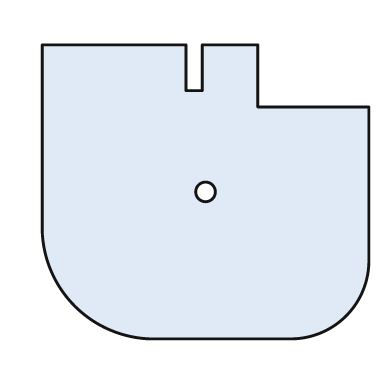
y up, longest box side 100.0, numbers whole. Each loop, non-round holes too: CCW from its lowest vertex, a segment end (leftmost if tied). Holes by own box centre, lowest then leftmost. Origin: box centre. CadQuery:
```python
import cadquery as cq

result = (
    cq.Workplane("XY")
    .moveTo(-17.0, -45.0)
    .lineTo(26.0, -45.0)
    .threePointArc((43.0, -38.0), (50.0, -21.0))
    .lineTo(50.0, 26.0)
    .lineTo(16.0, 26.0)
    .lineTo(16.0, 45.0)
    .lineTo(-1.0, 45.0)
    .lineTo(-1.0, 31.0)
    .lineTo(-6.0, 31.0)
    .lineTo(-6.0, 45.0)
    .lineTo(-50.0, 45.0)
    .lineTo(-50.0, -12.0)
    .threePointArc((-40.0, -35.0), (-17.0, -45.0))
    .close()
    .moveTo(0.0, 0.0)
    .circle(3.0)
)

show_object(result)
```